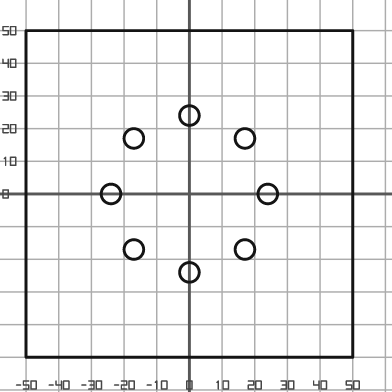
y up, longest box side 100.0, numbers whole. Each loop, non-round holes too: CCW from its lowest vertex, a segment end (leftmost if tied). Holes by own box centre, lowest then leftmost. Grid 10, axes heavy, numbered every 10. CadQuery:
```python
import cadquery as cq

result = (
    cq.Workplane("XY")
    .moveTo(-50.0, -50.0)
    .lineTo(50.0, -50.0)
    .lineTo(50.0, 50.0)
    .lineTo(-50.0, 50.0)
    .close()
    .moveTo(0.0, -24.0)
    .circle(3.0)
    .moveTo(-17.0, -17.0)
    .circle(3.0)
    .moveTo(17.0, -17.0)
    .circle(3.0)
    .moveTo(-24.0, 0.0)
    .circle(3.0)
    .moveTo(24.0, 0.0)
    .circle(3.0)
    .moveTo(-17.0, 17.0)
    .circle(3.0)
    .moveTo(17.0, 17.0)
    .circle(3.0)
    .moveTo(0.0, 24.0)
    .circle(3.0)
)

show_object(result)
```